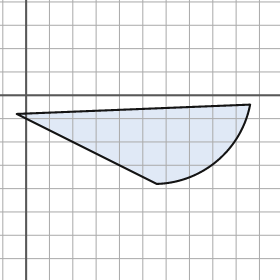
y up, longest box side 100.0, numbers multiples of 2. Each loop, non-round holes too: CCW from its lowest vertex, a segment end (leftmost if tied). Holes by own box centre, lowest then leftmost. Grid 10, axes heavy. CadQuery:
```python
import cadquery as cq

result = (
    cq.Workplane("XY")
    .moveTo(56.0, -38.0)
    .threePointArc((82.0, -28.0), (96.0, -4.0))
    .lineTo(-4.0, -8.0)
    .close()
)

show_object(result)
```